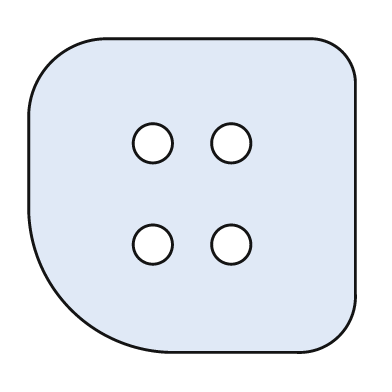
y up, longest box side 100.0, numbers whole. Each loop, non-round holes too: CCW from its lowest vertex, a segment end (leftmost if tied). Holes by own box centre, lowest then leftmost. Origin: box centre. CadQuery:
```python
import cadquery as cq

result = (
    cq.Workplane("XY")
    .moveTo(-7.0, -48.0)
    .lineTo(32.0, -48.0)
    .threePointArc((45.0, -43.0), (50.0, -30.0))
    .lineTo(50.0, 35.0)
    .threePointArc((46.0, 44.0), (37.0, 48.0))
    .lineTo(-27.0, 48.0)
    .threePointArc((-43.0, 41.0), (-50.0, 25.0))
    .lineTo(-50.0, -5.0)
    .threePointArc((-37.0, -35.0), (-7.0, -48.0))
    .close()
    .moveTo(-12.0, -15.0)
    .circle(6.0)
    .moveTo(12.0, -15.0)
    .circle(6.0)
    .moveTo(-12.0, 16.0)
    .circle(6.0)
    .moveTo(12.0, 16.0)
    .circle(6.0)
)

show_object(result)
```